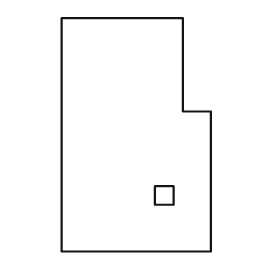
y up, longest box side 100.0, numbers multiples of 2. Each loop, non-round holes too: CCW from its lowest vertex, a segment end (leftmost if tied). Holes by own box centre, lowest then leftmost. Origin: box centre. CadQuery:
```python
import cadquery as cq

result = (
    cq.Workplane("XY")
    .moveTo(-32.0, -50.0)
    .lineTo(32.0, -50.0)
    .lineTo(32.0, 10.0)
    .lineTo(20.0, 10.0)
    .lineTo(20.0, 50.0)
    .lineTo(-32.0, 50.0)
    .close()
    .moveTo(8.0, -30.0)
    .lineTo(16.0, -30.0)
    .lineTo(16.0, -22.0)
    .lineTo(8.0, -22.0)
    .close()
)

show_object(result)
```